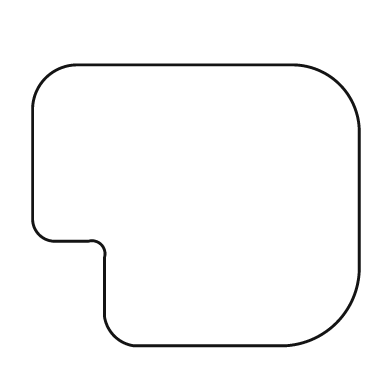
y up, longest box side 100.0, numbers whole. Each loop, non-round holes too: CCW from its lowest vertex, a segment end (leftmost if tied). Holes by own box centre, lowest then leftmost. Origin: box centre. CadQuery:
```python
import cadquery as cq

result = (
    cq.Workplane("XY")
    .moveTo(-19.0, -43.0)
    .lineTo(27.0, -43.0)
    .threePointArc((43.0, -36.0), (50.0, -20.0))
    .lineTo(50.0, 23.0)
    .threePointArc((44.0, 37.0), (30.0, 43.0))
    .lineTo(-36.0, 43.0)
    .threePointArc((-46.0, 39.0), (-50.0, 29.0))
    .lineTo(-50.0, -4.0)
    .threePointArc((-48.0, -9.0), (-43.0, -11.0))
    .lineTo(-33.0, -11.0)
    .threePointArc((-29.0, -12.0), (-28.0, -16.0))
    .lineTo(-28.0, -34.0)
    .threePointArc((-25.0, -40.0), (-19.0, -43.0))
    .close()
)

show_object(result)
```